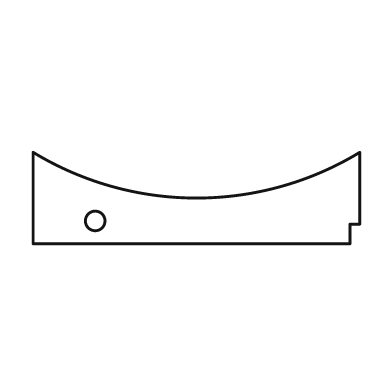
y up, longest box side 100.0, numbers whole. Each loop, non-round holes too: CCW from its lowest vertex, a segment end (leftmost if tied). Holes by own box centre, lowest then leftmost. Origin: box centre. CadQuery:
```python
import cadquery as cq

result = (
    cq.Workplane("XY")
    .moveTo(-50.0, -14.0)
    .lineTo(47.0, -14.0)
    .lineTo(47.0, -8.0)
    .lineTo(50.0, -8.0)
    .lineTo(50.0, 14.0)
    .threePointArc((0.0, 0.0), (-50.0, 14.0))
    .close()
    .moveTo(-31.0, -7.0)
    .circle(3.0)
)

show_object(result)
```